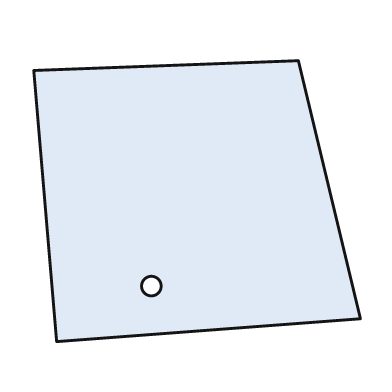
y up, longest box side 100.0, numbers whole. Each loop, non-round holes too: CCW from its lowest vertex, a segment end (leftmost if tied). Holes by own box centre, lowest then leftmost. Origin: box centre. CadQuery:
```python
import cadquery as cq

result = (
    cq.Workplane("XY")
    .moveTo(-43.0, -43.0)
    .lineTo(50.0, -36.0)
    .lineTo(31.0, 43.0)
    .lineTo(-50.0, 40.0)
    .close()
    .moveTo(-14.0, -26.0)
    .circle(3.0)
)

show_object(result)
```